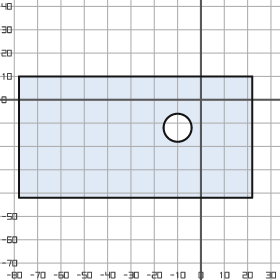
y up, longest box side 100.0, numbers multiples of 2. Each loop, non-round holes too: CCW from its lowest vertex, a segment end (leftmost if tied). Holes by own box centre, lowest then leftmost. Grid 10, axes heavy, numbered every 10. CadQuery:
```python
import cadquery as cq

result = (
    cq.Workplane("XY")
    .moveTo(-78.0, -42.0)
    .lineTo(22.0, -42.0)
    .lineTo(22.0, 10.0)
    .lineTo(-78.0, 10.0)
    .close()
    .moveTo(-10.0, -12.0)
    .circle(6.0)
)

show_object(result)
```